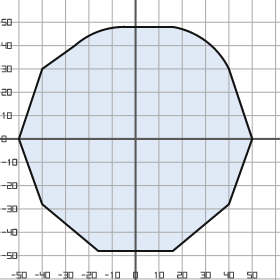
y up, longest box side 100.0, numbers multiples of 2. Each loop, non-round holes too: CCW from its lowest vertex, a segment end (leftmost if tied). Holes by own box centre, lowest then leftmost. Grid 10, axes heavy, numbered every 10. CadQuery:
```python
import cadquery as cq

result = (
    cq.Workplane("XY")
    .moveTo(-16.0, -48.0)
    .lineTo(16.0, -48.0)
    .lineTo(40.0, -28.0)
    .lineTo(50.0, 0.0)
    .lineTo(40.0, 30.0)
    .threePointArc((30.0, 42.0), (16.0, 48.0))
    .lineTo(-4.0, 48.0)
    .threePointArc((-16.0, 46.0), (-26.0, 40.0))
    .lineTo(-40.0, 30.0)
    .lineTo(-50.0, 0.0)
    .lineTo(-40.0, -28.0)
    .close()
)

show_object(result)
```